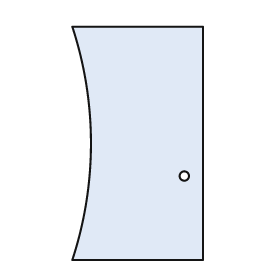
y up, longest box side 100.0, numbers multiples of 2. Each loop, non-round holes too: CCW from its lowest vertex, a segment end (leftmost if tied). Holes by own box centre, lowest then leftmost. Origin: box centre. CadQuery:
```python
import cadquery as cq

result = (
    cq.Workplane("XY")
    .moveTo(-28.0, -50.0)
    .lineTo(28.0, -50.0)
    .lineTo(28.0, 50.0)
    .lineTo(-28.0, 50.0)
    .threePointArc((-20.0, 0.0), (-28.0, -50.0))
    .close()
    .moveTo(20.0, -14.0)
    .circle(2.0)
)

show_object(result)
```